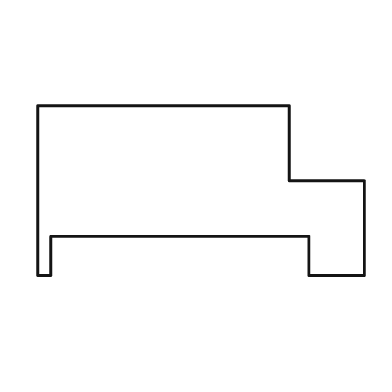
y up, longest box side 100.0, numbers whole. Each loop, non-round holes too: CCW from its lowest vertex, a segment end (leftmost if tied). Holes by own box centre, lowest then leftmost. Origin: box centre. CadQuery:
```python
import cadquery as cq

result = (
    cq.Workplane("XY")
    .moveTo(-50.0, -26.0)
    .lineTo(-46.0, -26.0)
    .lineTo(-46.0, -14.0)
    .lineTo(33.0, -14.0)
    .lineTo(33.0, -26.0)
    .lineTo(50.0, -26.0)
    .lineTo(50.0, 3.0)
    .lineTo(27.0, 3.0)
    .lineTo(27.0, 26.0)
    .lineTo(-50.0, 26.0)
    .close()
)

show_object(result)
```